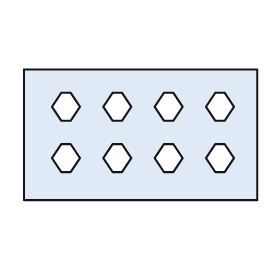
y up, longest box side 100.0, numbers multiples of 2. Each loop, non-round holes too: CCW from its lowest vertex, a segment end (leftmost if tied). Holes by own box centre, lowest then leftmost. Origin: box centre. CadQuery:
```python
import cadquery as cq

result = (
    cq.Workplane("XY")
    .moveTo(-50.0, -28.0)
    .lineTo(50.0, -28.0)
    .lineTo(50.0, 28.0)
    .lineTo(-50.0, 28.0)
    .close()
    .moveTo(-34.0, -16.0)
    .lineTo(-30.0, -16.0)
    .lineTo(-26.0, -10.0)
    .lineTo(-30.0, -4.0)
    .lineTo(-34.0, -4.0)
    .lineTo(-38.0, -10.0)
    .close()
    .moveTo(-12.0, -16.0)
    .lineTo(-8.0, -16.0)
    .lineTo(-4.0, -10.0)
    .lineTo(-8.0, -4.0)
    .lineTo(-12.0, -4.0)
    .lineTo(-16.0, -10.0)
    .close()
    .moveTo(10.0, -16.0)
    .lineTo(14.0, -16.0)
    .lineTo(18.0, -10.0)
    .lineTo(14.0, -4.0)
    .lineTo(10.0, -4.0)
    .lineTo(6.0, -10.0)
    .close()
    .moveTo(32.0, -16.0)
    .lineTo(36.0, -16.0)
    .lineTo(40.0, -10.0)
    .lineTo(36.0, -4.0)
    .lineTo(32.0, -4.0)
    .lineTo(28.0, -10.0)
    .close()
    .moveTo(-34.0, 6.0)
    .lineTo(-30.0, 6.0)
    .lineTo(-26.0, 12.0)
    .lineTo(-30.0, 18.0)
    .lineTo(-34.0, 18.0)
    .lineTo(-38.0, 12.0)
    .close()
    .moveTo(-12.0, 6.0)
    .lineTo(-8.0, 6.0)
    .lineTo(-4.0, 12.0)
    .lineTo(-8.0, 18.0)
    .lineTo(-12.0, 18.0)
    .lineTo(-16.0, 12.0)
    .close()
    .moveTo(10.0, 6.0)
    .lineTo(14.0, 6.0)
    .lineTo(18.0, 12.0)
    .lineTo(14.0, 18.0)
    .lineTo(10.0, 18.0)
    .lineTo(6.0, 12.0)
    .close()
    .moveTo(32.0, 6.0)
    .lineTo(36.0, 6.0)
    .lineTo(40.0, 12.0)
    .lineTo(36.0, 18.0)
    .lineTo(32.0, 18.0)
    .lineTo(28.0, 12.0)
    .close()
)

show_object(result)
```